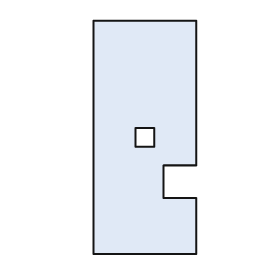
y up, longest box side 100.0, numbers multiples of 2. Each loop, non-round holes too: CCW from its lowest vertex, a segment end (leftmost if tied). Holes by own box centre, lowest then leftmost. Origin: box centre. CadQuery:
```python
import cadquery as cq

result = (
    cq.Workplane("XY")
    .moveTo(-22.0, -50.0)
    .lineTo(22.0, -50.0)
    .lineTo(22.0, -26.0)
    .lineTo(8.0, -26.0)
    .lineTo(8.0, -12.0)
    .lineTo(22.0, -12.0)
    .lineTo(22.0, 50.0)
    .lineTo(-22.0, 50.0)
    .close()
    .moveTo(-4.0, -4.0)
    .lineTo(4.0, -4.0)
    .lineTo(4.0, 4.0)
    .lineTo(-4.0, 4.0)
    .close()
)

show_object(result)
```